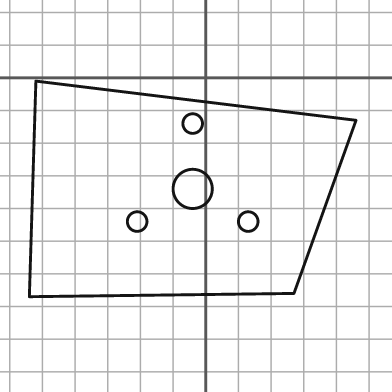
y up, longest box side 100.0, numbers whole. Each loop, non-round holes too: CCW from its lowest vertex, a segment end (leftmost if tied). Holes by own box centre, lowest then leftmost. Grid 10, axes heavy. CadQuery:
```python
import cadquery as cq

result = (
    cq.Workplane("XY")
    .moveTo(-54.0, -67.0)
    .lineTo(27.0, -66.0)
    .lineTo(46.0, -13.0)
    .lineTo(-52.0, -1.0)
    .close()
    .moveTo(-21.0, -44.0)
    .circle(3.0)
    .moveTo(13.0, -44.0)
    .circle(3.0)
    .moveTo(-4.0, -34.0)
    .circle(6.0)
    .moveTo(-4.0, -14.0)
    .circle(3.0)
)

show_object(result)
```